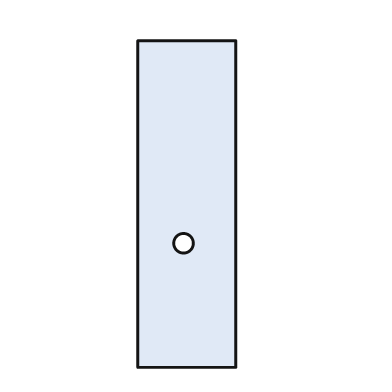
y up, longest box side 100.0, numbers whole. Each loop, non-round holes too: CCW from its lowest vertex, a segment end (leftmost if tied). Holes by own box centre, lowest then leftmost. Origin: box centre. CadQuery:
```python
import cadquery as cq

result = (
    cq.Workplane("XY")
    .moveTo(-15.0, -50.0)
    .lineTo(15.0, -50.0)
    .lineTo(15.0, 50.0)
    .lineTo(-15.0, 50.0)
    .close()
    .moveTo(-1.0, -12.0)
    .circle(3.0)
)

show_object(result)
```